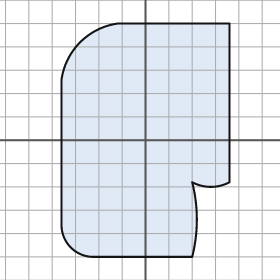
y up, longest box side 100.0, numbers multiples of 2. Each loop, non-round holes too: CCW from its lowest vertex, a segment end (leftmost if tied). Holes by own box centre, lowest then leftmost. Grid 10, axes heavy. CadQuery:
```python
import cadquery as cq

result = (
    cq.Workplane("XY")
    .moveTo(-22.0, -50.0)
    .lineTo(20.0, -50.0)
    .threePointArc((22.0, -34.0), (20.0, -18.0))
    .threePointArc((28.0, -20.0), (36.0, -18.0))
    .lineTo(36.0, 50.0)
    .lineTo(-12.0, 50.0)
    .threePointArc((-28.0, 42.0), (-36.0, 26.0))
    .lineTo(-36.0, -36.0)
    .threePointArc((-32.0, -46.0), (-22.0, -50.0))
    .close()
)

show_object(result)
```